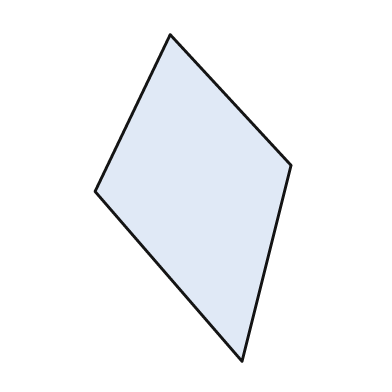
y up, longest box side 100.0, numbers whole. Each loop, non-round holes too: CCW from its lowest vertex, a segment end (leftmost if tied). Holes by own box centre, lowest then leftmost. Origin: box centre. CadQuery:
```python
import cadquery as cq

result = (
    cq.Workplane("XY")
    .moveTo(15.0, -50.0)
    .lineTo(30.0, 10.0)
    .lineTo(-7.0, 50.0)
    .lineTo(-30.0, 2.0)
    .close()
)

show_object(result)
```